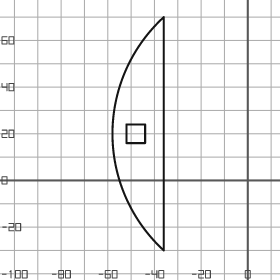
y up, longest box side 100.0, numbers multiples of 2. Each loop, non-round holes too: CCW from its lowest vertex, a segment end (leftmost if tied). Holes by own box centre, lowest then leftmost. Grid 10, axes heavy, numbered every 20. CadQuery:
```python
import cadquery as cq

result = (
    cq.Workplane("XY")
    .moveTo(-36.0, -30.0)
    .lineTo(-36.0, 70.0)
    .threePointArc((-58.0, 20.0), (-36.0, -30.0))
    .close()
    .moveTo(-52.0, 16.0)
    .lineTo(-44.0, 16.0)
    .lineTo(-44.0, 24.0)
    .lineTo(-52.0, 24.0)
    .close()
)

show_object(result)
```